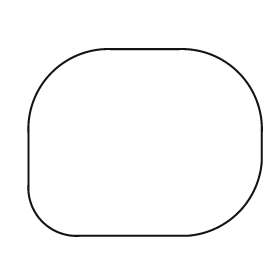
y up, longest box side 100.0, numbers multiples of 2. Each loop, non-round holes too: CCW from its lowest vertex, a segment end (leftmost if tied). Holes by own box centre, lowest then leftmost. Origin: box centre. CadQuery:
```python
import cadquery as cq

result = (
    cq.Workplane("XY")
    .moveTo(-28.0, -40.0)
    .lineTo(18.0, -40.0)
    .threePointArc((40.0, -30.0), (50.0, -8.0))
    .lineTo(50.0, 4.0)
    .threePointArc((40.0, 30.0), (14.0, 40.0))
    .lineTo(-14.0, 40.0)
    .threePointArc((-40.0, 30.0), (-50.0, 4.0))
    .lineTo(-50.0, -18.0)
    .threePointArc((-44.0, -34.0), (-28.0, -40.0))
    .close()
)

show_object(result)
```